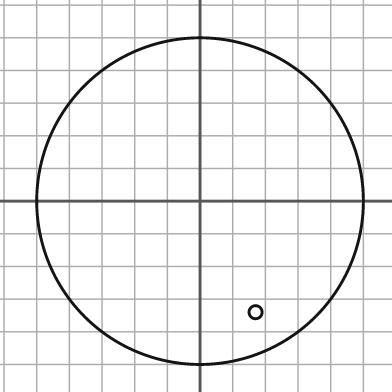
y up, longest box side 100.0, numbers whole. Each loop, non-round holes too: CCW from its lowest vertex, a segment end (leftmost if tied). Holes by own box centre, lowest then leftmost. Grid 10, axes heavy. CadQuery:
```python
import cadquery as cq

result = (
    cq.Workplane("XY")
    .moveTo(0.0, 0.0)
    .circle(50.0)
    .moveTo(17.0, -34.0)
    .circle(2.0)
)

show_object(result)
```